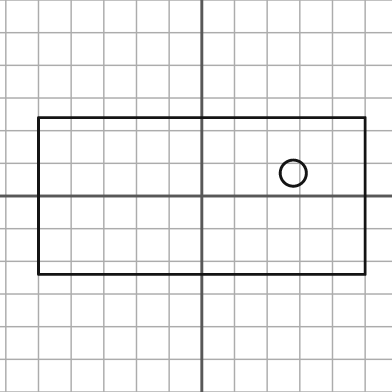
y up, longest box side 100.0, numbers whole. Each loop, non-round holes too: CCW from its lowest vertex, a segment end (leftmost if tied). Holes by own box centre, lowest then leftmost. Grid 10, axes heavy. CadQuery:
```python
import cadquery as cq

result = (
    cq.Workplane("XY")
    .moveTo(-50.0, -24.0)
    .lineTo(50.0, -24.0)
    .lineTo(50.0, 24.0)
    .lineTo(-50.0, 24.0)
    .close()
    .moveTo(28.0, 7.0)
    .circle(4.0)
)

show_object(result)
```